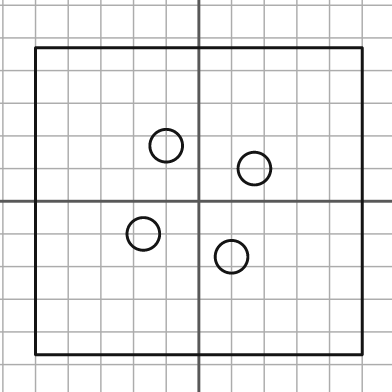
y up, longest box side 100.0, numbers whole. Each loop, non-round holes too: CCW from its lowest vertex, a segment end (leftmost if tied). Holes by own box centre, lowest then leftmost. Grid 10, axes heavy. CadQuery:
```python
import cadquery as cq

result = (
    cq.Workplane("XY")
    .moveTo(-50.0, -47.0)
    .lineTo(50.0, -47.0)
    .lineTo(50.0, 47.0)
    .lineTo(-50.0, 47.0)
    .close()
    .moveTo(10.0, -17.0)
    .circle(5.0)
    .moveTo(-17.0, -10.0)
    .circle(5.0)
    .moveTo(17.0, 10.0)
    .circle(5.0)
    .moveTo(-10.0, 17.0)
    .circle(5.0)
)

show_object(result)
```